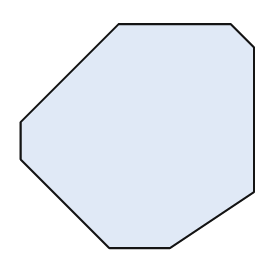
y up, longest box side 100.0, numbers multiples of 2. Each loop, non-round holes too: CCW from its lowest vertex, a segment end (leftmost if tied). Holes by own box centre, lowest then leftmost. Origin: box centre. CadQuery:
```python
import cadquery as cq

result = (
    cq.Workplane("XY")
    .moveTo(-12.0, -48.0)
    .lineTo(14.0, -48.0)
    .lineTo(50.0, -24.0)
    .lineTo(50.0, 38.0)
    .lineTo(40.0, 48.0)
    .lineTo(-8.0, 48.0)
    .lineTo(-50.0, 6.0)
    .lineTo(-50.0, -10.0)
    .close()
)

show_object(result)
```